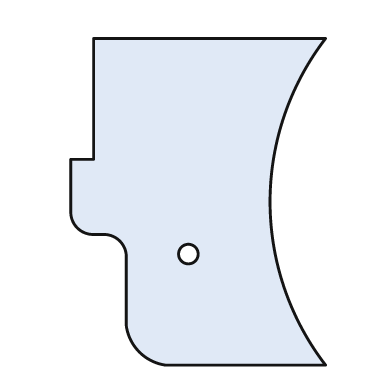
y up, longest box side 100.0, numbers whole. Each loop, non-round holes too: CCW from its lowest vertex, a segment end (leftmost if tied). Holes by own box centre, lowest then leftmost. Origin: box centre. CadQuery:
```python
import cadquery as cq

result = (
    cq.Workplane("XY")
    .moveTo(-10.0, -50.0)
    .lineTo(39.0, -50.0)
    .threePointArc((22.0, 0.0), (39.0, 50.0))
    .lineTo(-32.0, 50.0)
    .lineTo(-32.0, 13.0)
    .lineTo(-39.0, 13.0)
    .lineTo(-39.0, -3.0)
    .threePointArc((-37.0, -8.0), (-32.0, -10.0))
    .lineTo(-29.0, -10.0)
    .threePointArc((-24.0, -12.0), (-22.0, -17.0))
    .lineTo(-22.0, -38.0)
    .threePointArc((-18.0, -46.0), (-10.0, -50.0))
    .close()
    .moveTo(-3.0, -16.0)
    .circle(3.0)
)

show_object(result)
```